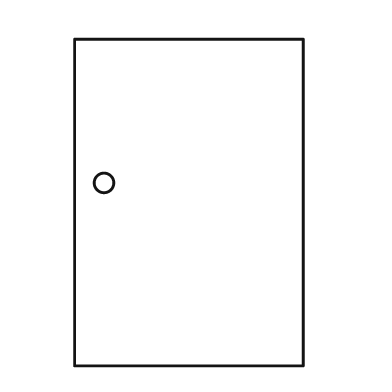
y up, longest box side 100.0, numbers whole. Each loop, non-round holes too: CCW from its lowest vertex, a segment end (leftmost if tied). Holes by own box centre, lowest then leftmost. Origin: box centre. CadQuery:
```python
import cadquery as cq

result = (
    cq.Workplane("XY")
    .moveTo(-35.0, -50.0)
    .lineTo(35.0, -50.0)
    .lineTo(35.0, 50.0)
    .lineTo(-35.0, 50.0)
    .close()
    .moveTo(-26.0, 6.0)
    .circle(3.0)
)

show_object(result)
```